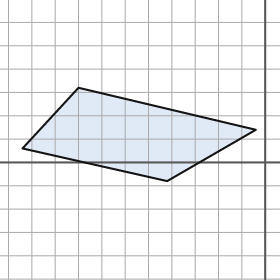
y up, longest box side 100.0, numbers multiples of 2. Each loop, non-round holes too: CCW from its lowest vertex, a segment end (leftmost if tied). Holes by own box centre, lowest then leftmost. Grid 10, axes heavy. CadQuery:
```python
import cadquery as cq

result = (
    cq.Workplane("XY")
    .moveTo(-42.0, -8.0)
    .lineTo(-4.0, 14.0)
    .lineTo(-80.0, 32.0)
    .lineTo(-104.0, 6.0)
    .close()
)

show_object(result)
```